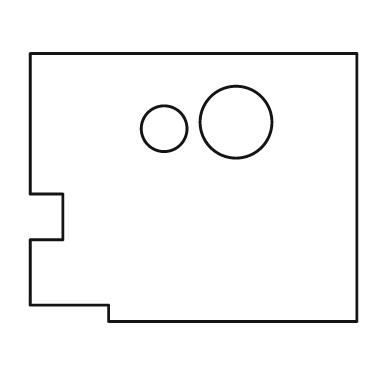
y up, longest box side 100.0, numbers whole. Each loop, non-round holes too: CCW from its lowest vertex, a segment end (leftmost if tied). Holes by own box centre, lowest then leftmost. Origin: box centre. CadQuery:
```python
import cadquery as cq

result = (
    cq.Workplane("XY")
    .moveTo(-26.0, -41.0)
    .lineTo(50.0, -41.0)
    .lineTo(50.0, 41.0)
    .lineTo(-50.0, 41.0)
    .lineTo(-50.0, -2.0)
    .lineTo(-40.0, -2.0)
    .lineTo(-40.0, -16.0)
    .lineTo(-50.0, -16.0)
    .lineTo(-50.0, -36.0)
    .lineTo(-26.0, -36.0)
    .close()
    .moveTo(-9.0, 18.0)
    .circle(7.0)
    .moveTo(13.0, 20.0)
    .circle(11.0)
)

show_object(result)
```